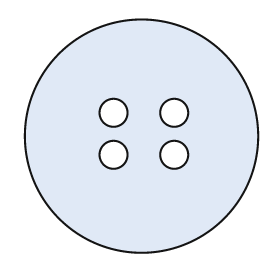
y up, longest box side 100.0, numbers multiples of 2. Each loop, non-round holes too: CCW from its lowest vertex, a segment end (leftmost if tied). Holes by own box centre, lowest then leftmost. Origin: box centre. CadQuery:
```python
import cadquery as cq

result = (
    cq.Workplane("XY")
    .moveTo(0.0, 0.0)
    .circle(50.0)
    .moveTo(-12.0, -8.0)
    .circle(6.0)
    .moveTo(14.0, -8.0)
    .circle(6.0)
    .moveTo(-12.0, 10.0)
    .circle(6.0)
    .moveTo(14.0, 10.0)
    .circle(6.0)
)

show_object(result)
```